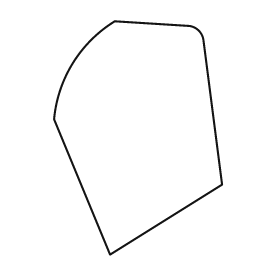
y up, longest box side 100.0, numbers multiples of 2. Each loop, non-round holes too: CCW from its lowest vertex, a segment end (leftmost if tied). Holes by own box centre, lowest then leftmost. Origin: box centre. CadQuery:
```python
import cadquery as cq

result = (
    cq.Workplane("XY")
    .moveTo(-12.0, -50.0)
    .lineTo(36.0, -20.0)
    .lineTo(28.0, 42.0)
    .threePointArc((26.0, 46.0), (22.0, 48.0))
    .lineTo(-10.0, 50.0)
    .threePointArc((-28.0, 32.0), (-36.0, 8.0))
    .close()
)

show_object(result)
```